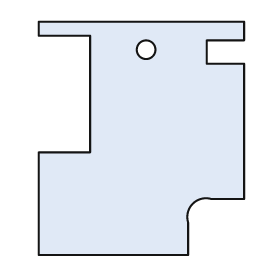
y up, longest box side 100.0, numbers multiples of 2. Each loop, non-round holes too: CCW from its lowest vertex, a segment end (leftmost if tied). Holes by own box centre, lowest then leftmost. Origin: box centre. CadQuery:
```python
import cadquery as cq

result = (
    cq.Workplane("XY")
    .moveTo(-44.0, -50.0)
    .lineTo(20.0, -50.0)
    .lineTo(20.0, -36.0)
    .threePointArc((22.0, -28.0), (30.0, -26.0))
    .lineTo(44.0, -26.0)
    .lineTo(44.0, 32.0)
    .lineTo(28.0, 32.0)
    .lineTo(28.0, 42.0)
    .lineTo(44.0, 42.0)
    .lineTo(44.0, 50.0)
    .lineTo(-44.0, 50.0)
    .lineTo(-44.0, 44.0)
    .lineTo(-22.0, 44.0)
    .lineTo(-22.0, -6.0)
    .lineTo(-44.0, -6.0)
    .close()
    .moveTo(2.0, 38.0)
    .circle(4.0)
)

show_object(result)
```